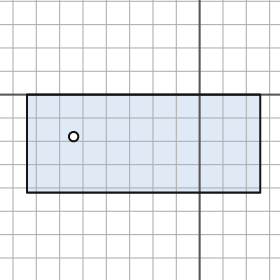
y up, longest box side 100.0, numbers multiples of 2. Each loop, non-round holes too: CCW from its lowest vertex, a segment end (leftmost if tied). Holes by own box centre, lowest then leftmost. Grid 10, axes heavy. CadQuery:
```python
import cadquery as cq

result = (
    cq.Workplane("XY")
    .moveTo(-74.0, -42.0)
    .lineTo(26.0, -42.0)
    .lineTo(26.0, 0.0)
    .lineTo(-74.0, 0.0)
    .close()
    .moveTo(-54.0, -18.0)
    .circle(2.0)
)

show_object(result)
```